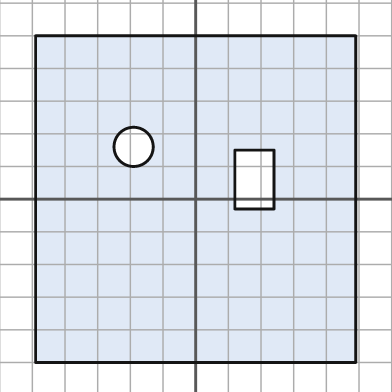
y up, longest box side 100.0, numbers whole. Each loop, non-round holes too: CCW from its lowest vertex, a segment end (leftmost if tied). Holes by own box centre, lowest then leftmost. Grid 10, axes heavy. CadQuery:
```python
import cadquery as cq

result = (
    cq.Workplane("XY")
    .moveTo(-49.0, -50.0)
    .lineTo(49.0, -50.0)
    .lineTo(49.0, 50.0)
    .lineTo(-49.0, 50.0)
    .close()
    .moveTo(12.0, -3.0)
    .lineTo(24.0, -3.0)
    .lineTo(24.0, 15.0)
    .lineTo(12.0, 15.0)
    .close()
    .moveTo(-19.0, 16.0)
    .circle(6.0)
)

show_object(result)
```